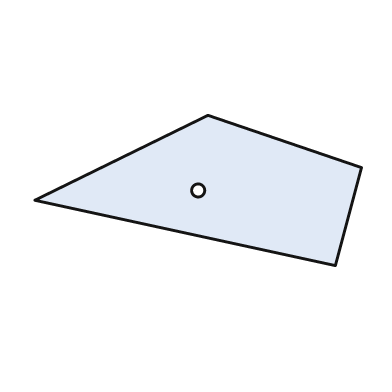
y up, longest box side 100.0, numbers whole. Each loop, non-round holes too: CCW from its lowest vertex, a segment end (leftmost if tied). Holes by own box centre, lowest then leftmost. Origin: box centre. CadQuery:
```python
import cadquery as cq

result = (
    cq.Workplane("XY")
    .moveTo(42.0, -23.0)
    .lineTo(50.0, 7.0)
    .lineTo(3.0, 23.0)
    .lineTo(-50.0, -3.0)
    .close()
    .moveTo(0.0, 0.0)
    .circle(2.0)
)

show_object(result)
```